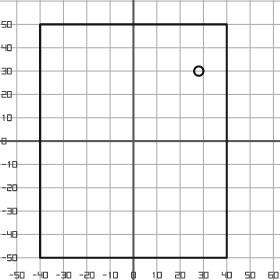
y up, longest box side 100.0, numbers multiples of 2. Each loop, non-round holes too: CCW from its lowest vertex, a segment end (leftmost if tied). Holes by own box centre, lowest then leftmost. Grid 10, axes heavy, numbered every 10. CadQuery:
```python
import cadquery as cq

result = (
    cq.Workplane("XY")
    .moveTo(-40.0, -50.0)
    .lineTo(40.0, -50.0)
    .lineTo(40.0, 50.0)
    .lineTo(-40.0, 50.0)
    .close()
    .moveTo(28.0, 30.0)
    .circle(2.0)
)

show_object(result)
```